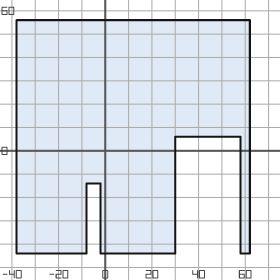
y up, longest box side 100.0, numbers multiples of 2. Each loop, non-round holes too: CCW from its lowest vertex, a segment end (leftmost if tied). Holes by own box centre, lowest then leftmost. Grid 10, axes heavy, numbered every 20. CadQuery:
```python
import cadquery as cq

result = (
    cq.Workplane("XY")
    .moveTo(-38.0, -44.0)
    .lineTo(-8.0, -44.0)
    .lineTo(-8.0, -14.0)
    .lineTo(-2.0, -14.0)
    .lineTo(-2.0, -44.0)
    .lineTo(30.0, -44.0)
    .lineTo(30.0, 6.0)
    .lineTo(58.0, 6.0)
    .lineTo(58.0, -44.0)
    .lineTo(62.0, -44.0)
    .lineTo(62.0, 56.0)
    .lineTo(-38.0, 56.0)
    .close()
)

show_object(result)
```